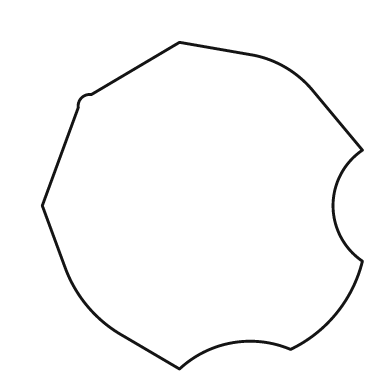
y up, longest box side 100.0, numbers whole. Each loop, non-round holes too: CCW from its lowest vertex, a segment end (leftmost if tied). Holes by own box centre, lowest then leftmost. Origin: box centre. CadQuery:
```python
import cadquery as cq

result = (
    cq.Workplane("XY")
    .moveTo(-7.0, -50.0)
    .threePointArc((9.0, -42.0), (27.0, -44.0))
    .threePointArc((41.0, -33.0), (49.0, -17.0))
    .threePointArc((40.0, 0.0), (49.0, 17.0))
    .lineTo(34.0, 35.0)
    .threePointArc((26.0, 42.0), (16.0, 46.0))
    .lineTo(-7.0, 50.0)
    .lineTo(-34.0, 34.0)
    .threePointArc((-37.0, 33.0), (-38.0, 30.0))
    .lineTo(-49.0, 0.0)
    .lineTo(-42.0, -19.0)
    .threePointArc((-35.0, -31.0), (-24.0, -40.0))
    .close()
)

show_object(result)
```